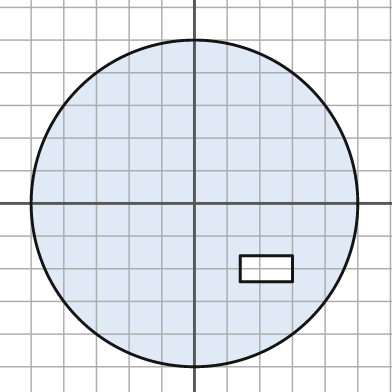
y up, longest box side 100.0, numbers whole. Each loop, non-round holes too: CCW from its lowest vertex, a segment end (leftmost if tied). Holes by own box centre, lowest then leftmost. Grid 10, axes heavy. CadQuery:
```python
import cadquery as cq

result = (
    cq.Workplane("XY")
    .moveTo(0.0, 0.0)
    .circle(50.0)
    .moveTo(14.0, -24.0)
    .lineTo(30.0, -24.0)
    .lineTo(30.0, -16.0)
    .lineTo(14.0, -16.0)
    .close()
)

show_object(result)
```